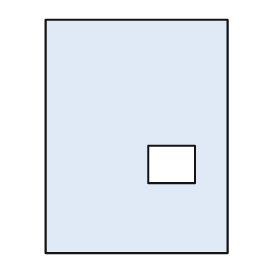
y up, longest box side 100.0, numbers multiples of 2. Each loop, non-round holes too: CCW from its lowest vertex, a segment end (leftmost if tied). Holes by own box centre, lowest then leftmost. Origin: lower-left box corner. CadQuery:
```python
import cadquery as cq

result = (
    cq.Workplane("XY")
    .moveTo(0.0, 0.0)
    .lineTo(78.0, 0.0)
    .lineTo(78.0, 100.0)
    .lineTo(0.0, 100.0)
    .close()
    .moveTo(44.0, 30.0)
    .lineTo(64.0, 30.0)
    .lineTo(64.0, 46.0)
    .lineTo(44.0, 46.0)
    .close()
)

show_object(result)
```